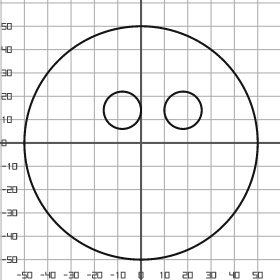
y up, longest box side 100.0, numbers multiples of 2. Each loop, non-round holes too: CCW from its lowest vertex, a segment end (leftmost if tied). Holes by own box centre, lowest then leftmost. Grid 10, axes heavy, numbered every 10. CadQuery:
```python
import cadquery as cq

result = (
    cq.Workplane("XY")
    .moveTo(0.0, 0.0)
    .circle(50.0)
    .moveTo(-8.0, 14.0)
    .circle(8.0)
    .moveTo(18.0, 14.0)
    .circle(8.0)
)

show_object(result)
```